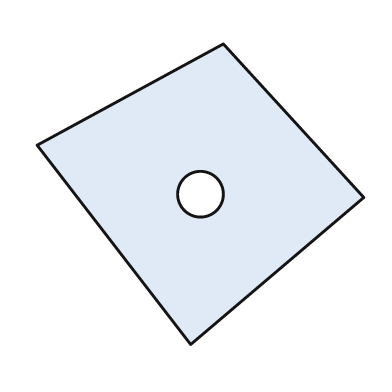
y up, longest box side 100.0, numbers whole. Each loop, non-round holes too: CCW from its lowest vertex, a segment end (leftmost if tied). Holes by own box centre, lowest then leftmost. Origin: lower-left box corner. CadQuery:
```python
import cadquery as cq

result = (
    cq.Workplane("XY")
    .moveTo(47.0, 0.0)
    .lineTo(100.0, 45.0)
    .lineTo(57.0, 92.0)
    .lineTo(0.0, 61.0)
    .close()
    .moveTo(50.0, 46.0)
    .circle(7.0)
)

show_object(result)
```